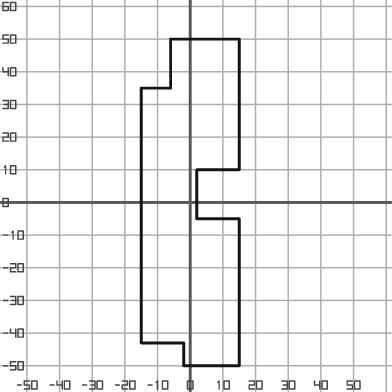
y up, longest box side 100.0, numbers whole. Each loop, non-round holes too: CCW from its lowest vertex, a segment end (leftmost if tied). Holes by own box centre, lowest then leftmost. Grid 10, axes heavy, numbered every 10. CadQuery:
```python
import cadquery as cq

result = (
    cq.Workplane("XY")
    .moveTo(-2.0, -50.0)
    .lineTo(15.0, -50.0)
    .lineTo(15.0, -5.0)
    .lineTo(2.0, -5.0)
    .lineTo(2.0, 10.0)
    .lineTo(15.0, 10.0)
    .lineTo(15.0, 50.0)
    .lineTo(-6.0, 50.0)
    .lineTo(-6.0, 35.0)
    .lineTo(-15.0, 35.0)
    .lineTo(-15.0, -43.0)
    .lineTo(-2.0, -43.0)
    .close()
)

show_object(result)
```